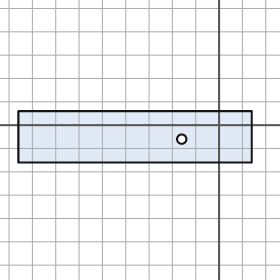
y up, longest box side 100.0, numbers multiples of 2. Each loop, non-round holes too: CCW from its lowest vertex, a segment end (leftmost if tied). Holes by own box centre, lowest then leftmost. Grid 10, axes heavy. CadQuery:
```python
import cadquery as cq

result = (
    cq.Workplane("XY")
    .moveTo(-86.0, -16.0)
    .lineTo(14.0, -16.0)
    .lineTo(14.0, 6.0)
    .lineTo(-86.0, 6.0)
    .close()
    .moveTo(-16.0, -6.0)
    .circle(2.0)
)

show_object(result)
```